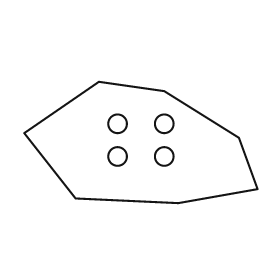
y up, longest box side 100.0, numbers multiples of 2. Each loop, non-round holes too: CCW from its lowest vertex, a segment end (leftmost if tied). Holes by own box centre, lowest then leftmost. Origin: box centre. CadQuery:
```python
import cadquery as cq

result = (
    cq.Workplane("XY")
    .moveTo(16.0, -26.0)
    .lineTo(50.0, -20.0)
    .lineTo(42.0, 2.0)
    .lineTo(10.0, 22.0)
    .lineTo(-18.0, 26.0)
    .lineTo(-50.0, 4.0)
    .lineTo(-28.0, -24.0)
    .close()
    .moveTo(-10.0, -6.0)
    .circle(4.0)
    .moveTo(10.0, -6.0)
    .circle(4.0)
    .moveTo(-10.0, 8.0)
    .circle(4.0)
    .moveTo(10.0, 8.0)
    .circle(4.0)
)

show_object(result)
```